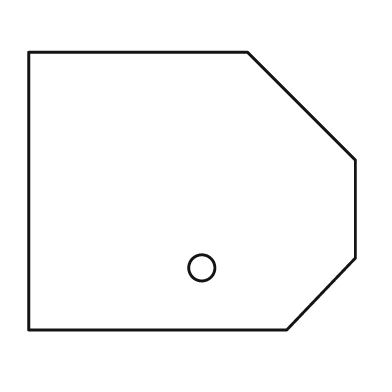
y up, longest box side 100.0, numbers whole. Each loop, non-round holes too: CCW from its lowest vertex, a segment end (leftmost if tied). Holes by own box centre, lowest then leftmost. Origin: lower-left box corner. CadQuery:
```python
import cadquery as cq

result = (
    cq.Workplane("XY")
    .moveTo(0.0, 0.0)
    .lineTo(79.0, 0.0)
    .lineTo(100.0, 22.0)
    .lineTo(100.0, 52.0)
    .lineTo(67.0, 85.0)
    .lineTo(0.0, 85.0)
    .close()
    .moveTo(53.0, 19.0)
    .circle(4.0)
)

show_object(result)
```